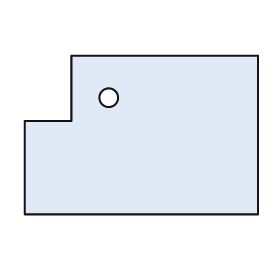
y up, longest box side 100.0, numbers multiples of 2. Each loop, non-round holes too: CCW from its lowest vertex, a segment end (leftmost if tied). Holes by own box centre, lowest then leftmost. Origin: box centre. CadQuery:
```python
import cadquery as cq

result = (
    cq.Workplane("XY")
    .moveTo(-50.0, -34.0)
    .lineTo(50.0, -34.0)
    .lineTo(50.0, 34.0)
    .lineTo(-30.0, 34.0)
    .lineTo(-30.0, 6.0)
    .lineTo(-50.0, 6.0)
    .close()
    .moveTo(-14.0, 16.0)
    .circle(4.0)
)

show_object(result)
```